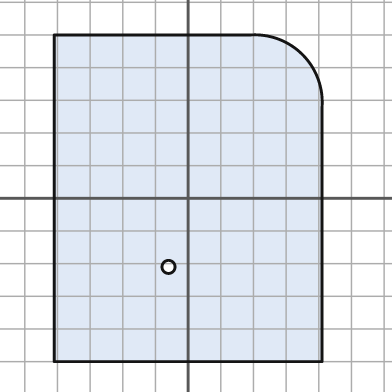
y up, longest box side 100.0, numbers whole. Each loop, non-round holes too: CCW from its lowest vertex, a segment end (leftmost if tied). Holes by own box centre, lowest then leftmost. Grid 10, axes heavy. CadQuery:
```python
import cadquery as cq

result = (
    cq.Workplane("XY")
    .moveTo(-41.0, -50.0)
    .lineTo(41.0, -50.0)
    .lineTo(41.0, 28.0)
    .threePointArc((35.0, 44.0), (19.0, 50.0))
    .lineTo(-41.0, 50.0)
    .close()
    .moveTo(-6.0, -21.0)
    .circle(2.0)
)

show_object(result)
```